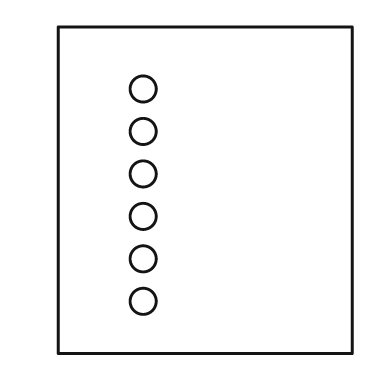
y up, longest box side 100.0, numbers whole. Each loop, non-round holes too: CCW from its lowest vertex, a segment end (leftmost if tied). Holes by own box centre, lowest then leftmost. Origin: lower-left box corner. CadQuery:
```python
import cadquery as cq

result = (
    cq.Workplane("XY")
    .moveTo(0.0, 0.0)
    .lineTo(90.0, 0.0)
    .lineTo(90.0, 100.0)
    .lineTo(0.0, 100.0)
    .close()
    .moveTo(26.0, 16.0)
    .circle(4.0)
    .moveTo(26.0, 29.0)
    .circle(4.0)
    .moveTo(26.0, 42.0)
    .circle(4.0)
    .moveTo(26.0, 55.0)
    .circle(4.0)
    .moveTo(26.0, 68.0)
    .circle(4.0)
    .moveTo(26.0, 81.0)
    .circle(4.0)
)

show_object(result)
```